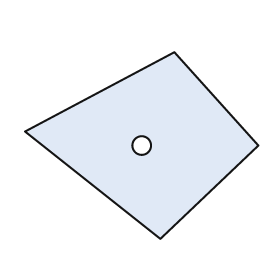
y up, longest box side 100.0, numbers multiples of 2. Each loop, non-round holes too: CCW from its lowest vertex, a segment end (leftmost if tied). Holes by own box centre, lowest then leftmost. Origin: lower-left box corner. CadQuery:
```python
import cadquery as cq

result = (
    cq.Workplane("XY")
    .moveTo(58.0, 0.0)
    .lineTo(100.0, 40.0)
    .lineTo(64.0, 80.0)
    .lineTo(0.0, 46.0)
    .close()
    .moveTo(50.0, 40.0)
    .circle(4.0)
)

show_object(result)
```